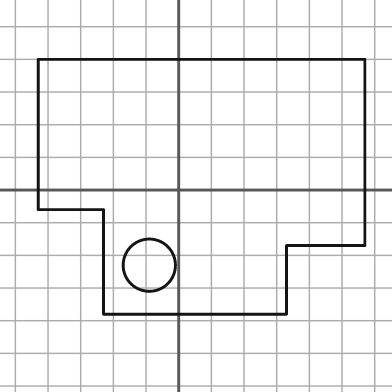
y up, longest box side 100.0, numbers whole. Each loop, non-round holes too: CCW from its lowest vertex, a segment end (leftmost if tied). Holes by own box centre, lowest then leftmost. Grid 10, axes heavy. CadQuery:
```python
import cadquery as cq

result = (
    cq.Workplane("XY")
    .moveTo(-23.0, -38.0)
    .lineTo(33.0, -38.0)
    .lineTo(33.0, -17.0)
    .lineTo(57.0, -17.0)
    .lineTo(57.0, 40.0)
    .lineTo(-43.0, 40.0)
    .lineTo(-43.0, -6.0)
    .lineTo(-23.0, -6.0)
    .close()
    .moveTo(-9.0, -23.0)
    .circle(8.0)
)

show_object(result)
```